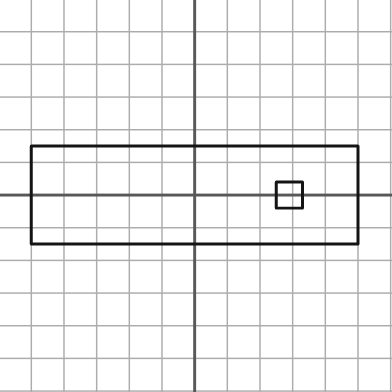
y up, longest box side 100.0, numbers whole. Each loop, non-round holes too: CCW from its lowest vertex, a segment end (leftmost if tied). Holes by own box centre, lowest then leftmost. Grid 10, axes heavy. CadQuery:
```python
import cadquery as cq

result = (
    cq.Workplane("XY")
    .moveTo(-50.0, -15.0)
    .lineTo(50.0, -15.0)
    .lineTo(50.0, 15.0)
    .lineTo(-50.0, 15.0)
    .close()
    .moveTo(25.0, -4.0)
    .lineTo(33.0, -4.0)
    .lineTo(33.0, 4.0)
    .lineTo(25.0, 4.0)
    .close()
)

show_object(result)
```